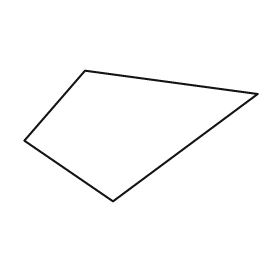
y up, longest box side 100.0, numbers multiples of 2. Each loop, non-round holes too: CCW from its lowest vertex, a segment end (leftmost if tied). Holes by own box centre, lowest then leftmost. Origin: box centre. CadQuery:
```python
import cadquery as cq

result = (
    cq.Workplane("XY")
    .moveTo(-12.0, -28.0)
    .lineTo(50.0, 18.0)
    .lineTo(-24.0, 28.0)
    .lineTo(-50.0, -2.0)
    .close()
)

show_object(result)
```